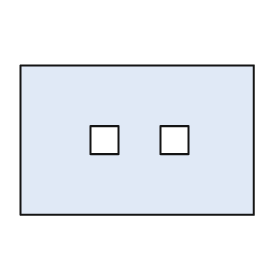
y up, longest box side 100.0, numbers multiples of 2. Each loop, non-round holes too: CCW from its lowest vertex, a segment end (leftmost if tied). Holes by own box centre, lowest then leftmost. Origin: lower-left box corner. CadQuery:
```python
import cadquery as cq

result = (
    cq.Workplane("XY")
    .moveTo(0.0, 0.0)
    .lineTo(100.0, 0.0)
    .lineTo(100.0, 64.0)
    .lineTo(0.0, 64.0)
    .close()
    .moveTo(30.0, 26.0)
    .lineTo(42.0, 26.0)
    .lineTo(42.0, 38.0)
    .lineTo(30.0, 38.0)
    .close()
    .moveTo(60.0, 26.0)
    .lineTo(72.0, 26.0)
    .lineTo(72.0, 38.0)
    .lineTo(60.0, 38.0)
    .close()
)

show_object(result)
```